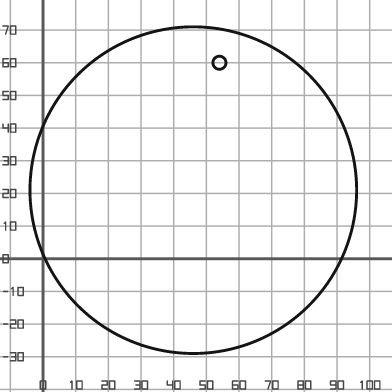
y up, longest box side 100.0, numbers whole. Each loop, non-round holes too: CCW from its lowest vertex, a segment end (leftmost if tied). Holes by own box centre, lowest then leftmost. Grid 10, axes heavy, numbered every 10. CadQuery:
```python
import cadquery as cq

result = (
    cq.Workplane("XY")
    .moveTo(46.0, 21.0)
    .circle(50.0)
    .moveTo(54.0, 60.0)
    .circle(2.0)
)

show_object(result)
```